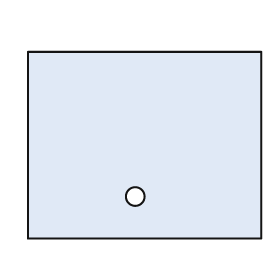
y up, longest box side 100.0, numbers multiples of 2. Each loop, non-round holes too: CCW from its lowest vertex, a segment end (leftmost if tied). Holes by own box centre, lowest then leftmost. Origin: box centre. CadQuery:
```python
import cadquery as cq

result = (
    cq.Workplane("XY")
    .moveTo(-50.0, -40.0)
    .lineTo(50.0, -40.0)
    .lineTo(50.0, 40.0)
    .lineTo(-50.0, 40.0)
    .close()
    .moveTo(-4.0, -22.0)
    .circle(4.0)
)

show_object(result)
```